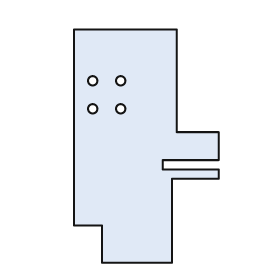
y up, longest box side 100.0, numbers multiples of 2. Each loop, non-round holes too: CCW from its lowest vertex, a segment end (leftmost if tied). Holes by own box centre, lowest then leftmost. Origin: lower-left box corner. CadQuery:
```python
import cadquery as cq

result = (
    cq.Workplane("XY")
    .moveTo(12.0, 0.0)
    .lineTo(42.0, 0.0)
    .lineTo(42.0, 36.0)
    .lineTo(62.0, 36.0)
    .lineTo(62.0, 40.0)
    .lineTo(38.0, 40.0)
    .lineTo(38.0, 44.0)
    .lineTo(62.0, 44.0)
    .lineTo(62.0, 56.0)
    .lineTo(44.0, 56.0)
    .lineTo(44.0, 100.0)
    .lineTo(0.0, 100.0)
    .lineTo(0.0, 16.0)
    .lineTo(12.0, 16.0)
    .close()
    .moveTo(8.0, 66.0)
    .circle(2.0)
    .moveTo(20.0, 66.0)
    .circle(2.0)
    .moveTo(8.0, 78.0)
    .circle(2.0)
    .moveTo(20.0, 78.0)
    .circle(2.0)
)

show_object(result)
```